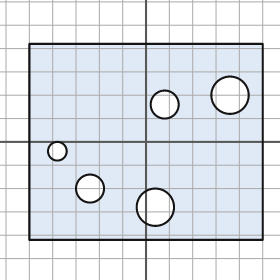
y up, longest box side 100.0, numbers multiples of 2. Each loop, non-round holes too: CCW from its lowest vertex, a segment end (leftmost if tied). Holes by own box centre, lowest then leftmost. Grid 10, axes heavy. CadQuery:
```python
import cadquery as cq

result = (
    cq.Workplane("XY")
    .moveTo(-50.0, -42.0)
    .lineTo(50.0, -42.0)
    .lineTo(50.0, 42.0)
    .lineTo(-50.0, 42.0)
    .close()
    .moveTo(4.0, -28.0)
    .circle(8.0)
    .moveTo(-24.0, -20.0)
    .circle(6.0)
    .moveTo(-38.0, -4.0)
    .circle(4.0)
    .moveTo(8.0, 16.0)
    .circle(6.0)
    .moveTo(36.0, 20.0)
    .circle(8.0)
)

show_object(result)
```